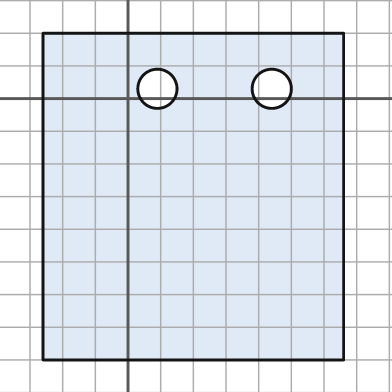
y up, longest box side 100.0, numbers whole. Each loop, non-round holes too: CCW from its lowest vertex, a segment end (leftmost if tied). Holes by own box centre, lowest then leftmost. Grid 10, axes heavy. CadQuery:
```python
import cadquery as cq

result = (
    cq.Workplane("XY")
    .moveTo(-26.0, -80.0)
    .lineTo(66.0, -80.0)
    .lineTo(66.0, 20.0)
    .lineTo(-26.0, 20.0)
    .close()
    .moveTo(9.0, 3.0)
    .circle(6.0)
    .moveTo(44.0, 3.0)
    .circle(6.0)
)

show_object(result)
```